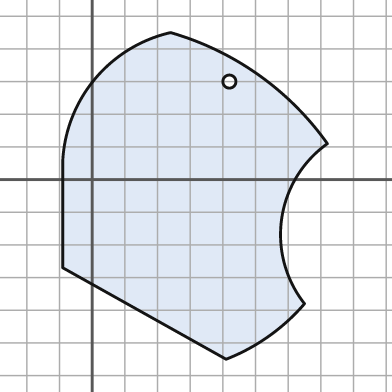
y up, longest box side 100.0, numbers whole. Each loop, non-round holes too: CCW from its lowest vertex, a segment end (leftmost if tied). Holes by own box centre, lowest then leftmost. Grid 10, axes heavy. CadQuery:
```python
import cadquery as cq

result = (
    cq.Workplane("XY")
    .moveTo(41.0, -55.0)
    .threePointArc((54.0, -48.0), (65.0, -38.0))
    .threePointArc((58.0, -12.0), (72.0, 11.0))
    .threePointArc((51.0, 32.0), (24.0, 45.0))
    .threePointArc((1.0, 31.0), (-9.0, 6.0))
    .lineTo(-9.0, -27.0)
    .close()
    .moveTo(42.0, 30.0)
    .circle(2.0)
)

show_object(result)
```